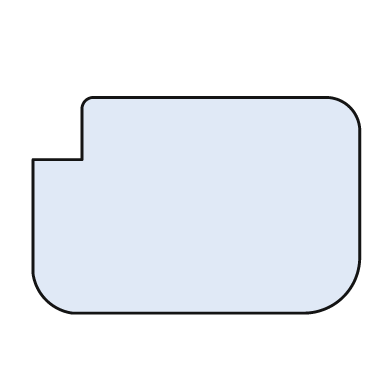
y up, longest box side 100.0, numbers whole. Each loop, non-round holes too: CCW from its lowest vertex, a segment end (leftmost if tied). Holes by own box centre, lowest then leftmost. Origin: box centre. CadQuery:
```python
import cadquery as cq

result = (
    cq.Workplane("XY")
    .moveTo(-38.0, -33.0)
    .lineTo(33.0, -33.0)
    .threePointArc((45.0, -28.0), (50.0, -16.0))
    .lineTo(50.0, 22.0)
    .threePointArc((47.0, 30.0), (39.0, 33.0))
    .lineTo(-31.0, 33.0)
    .threePointArc((-34.0, 32.0), (-35.0, 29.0))
    .lineTo(-35.0, 14.0)
    .lineTo(-50.0, 14.0)
    .lineTo(-50.0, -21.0)
    .threePointArc((-46.0, -29.0), (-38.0, -33.0))
    .close()
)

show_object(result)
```